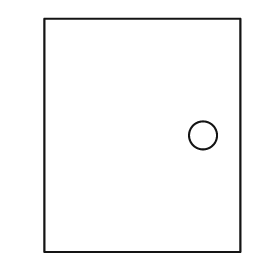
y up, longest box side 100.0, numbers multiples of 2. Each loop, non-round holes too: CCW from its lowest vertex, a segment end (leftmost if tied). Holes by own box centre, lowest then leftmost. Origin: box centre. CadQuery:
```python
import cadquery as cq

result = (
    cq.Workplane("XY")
    .moveTo(-42.0, -50.0)
    .lineTo(42.0, -50.0)
    .lineTo(42.0, 50.0)
    .lineTo(-42.0, 50.0)
    .close()
    .moveTo(26.0, 0.0)
    .circle(6.0)
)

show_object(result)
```